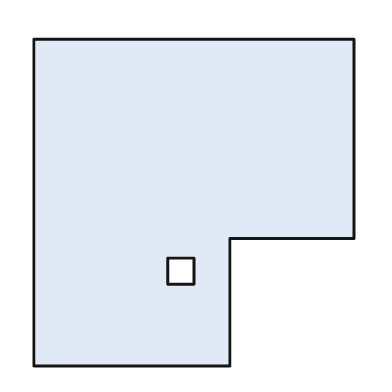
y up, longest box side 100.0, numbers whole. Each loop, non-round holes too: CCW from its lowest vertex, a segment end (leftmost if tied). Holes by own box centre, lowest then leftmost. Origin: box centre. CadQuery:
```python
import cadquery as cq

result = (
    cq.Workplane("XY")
    .moveTo(-49.0, -50.0)
    .lineTo(11.0, -50.0)
    .lineTo(11.0, -11.0)
    .lineTo(49.0, -11.0)
    .lineTo(49.0, 50.0)
    .lineTo(-49.0, 50.0)
    .close()
    .moveTo(-8.0, -25.0)
    .lineTo(0.0, -25.0)
    .lineTo(0.0, -17.0)
    .lineTo(-8.0, -17.0)
    .close()
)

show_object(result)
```